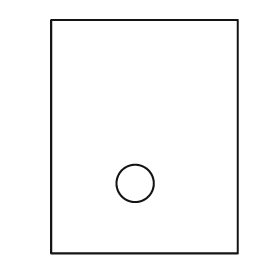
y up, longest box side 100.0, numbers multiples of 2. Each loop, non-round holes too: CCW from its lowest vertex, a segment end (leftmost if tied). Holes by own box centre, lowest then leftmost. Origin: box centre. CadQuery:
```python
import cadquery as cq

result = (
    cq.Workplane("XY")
    .moveTo(-40.0, -50.0)
    .lineTo(40.0, -50.0)
    .lineTo(40.0, 50.0)
    .lineTo(-40.0, 50.0)
    .close()
    .moveTo(-4.0, -20.0)
    .circle(8.0)
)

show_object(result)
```